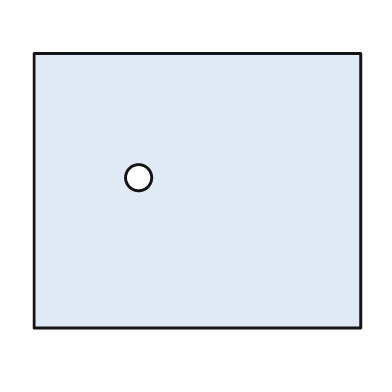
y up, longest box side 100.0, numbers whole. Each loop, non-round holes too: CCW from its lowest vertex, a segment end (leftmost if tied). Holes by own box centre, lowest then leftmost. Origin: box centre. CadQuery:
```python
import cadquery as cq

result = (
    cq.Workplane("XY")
    .moveTo(-50.0, -42.0)
    .lineTo(50.0, -42.0)
    .lineTo(50.0, 42.0)
    .lineTo(-50.0, 42.0)
    .close()
    .moveTo(-18.0, 4.0)
    .circle(4.0)
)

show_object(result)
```